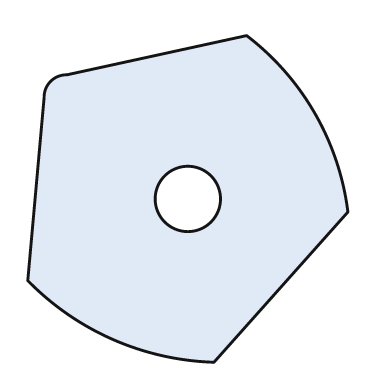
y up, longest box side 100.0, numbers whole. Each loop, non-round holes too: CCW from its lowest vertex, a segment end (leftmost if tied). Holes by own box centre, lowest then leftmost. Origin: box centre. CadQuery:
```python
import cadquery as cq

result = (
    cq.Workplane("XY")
    .moveTo(8.0, -50.0)
    .lineTo(49.0, -4.0)
    .threePointArc((39.0, 26.0), (18.0, 50.0))
    .lineTo(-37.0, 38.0)
    .threePointArc((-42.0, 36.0), (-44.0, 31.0))
    .lineTo(-49.0, -25.0)
    .threePointArc((-23.0, -43.0), (8.0, -50.0))
    .close()
    .moveTo(0.0, 0.0)
    .circle(10.0)
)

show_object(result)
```